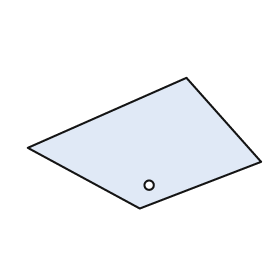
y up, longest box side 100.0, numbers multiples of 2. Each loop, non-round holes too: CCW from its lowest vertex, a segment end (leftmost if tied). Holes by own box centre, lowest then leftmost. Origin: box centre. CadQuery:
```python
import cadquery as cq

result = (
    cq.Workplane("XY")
    .moveTo(-2.0, -28.0)
    .lineTo(50.0, -8.0)
    .lineTo(18.0, 28.0)
    .lineTo(-50.0, -2.0)
    .close()
    .moveTo(2.0, -18.0)
    .circle(2.0)
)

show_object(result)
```